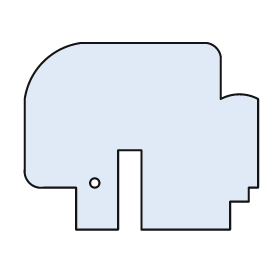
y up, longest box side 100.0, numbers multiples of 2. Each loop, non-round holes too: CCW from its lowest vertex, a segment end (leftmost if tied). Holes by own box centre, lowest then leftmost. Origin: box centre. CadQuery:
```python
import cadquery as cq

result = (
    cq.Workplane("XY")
    .moveTo(-28.0, -40.0)
    .lineTo(-10.0, -40.0)
    .lineTo(-10.0, -6.0)
    .lineTo(0.0, -6.0)
    .lineTo(0.0, -40.0)
    .lineTo(38.0, -40.0)
    .lineTo(38.0, -28.0)
    .lineTo(46.0, -28.0)
    .lineTo(46.0, -22.0)
    .lineTo(50.0, -22.0)
    .lineTo(50.0, 16.0)
    .threePointArc((42.0, 18.0), (34.0, 16.0))
    .lineTo(34.0, 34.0)
    .threePointArc((32.0, 38.0), (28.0, 40.0))
    .lineTo(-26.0, 40.0)
    .threePointArc((-42.0, 32.0), (-50.0, 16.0))
    .lineTo(-50.0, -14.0)
    .threePointArc((-48.0, -20.0), (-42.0, -22.0))
    .lineTo(-28.0, -22.0)
    .close()
    .moveTo(-20.0, -20.0)
    .circle(2.0)
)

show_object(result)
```